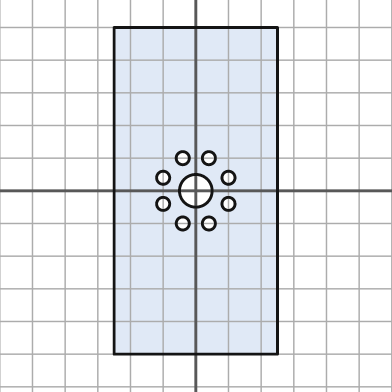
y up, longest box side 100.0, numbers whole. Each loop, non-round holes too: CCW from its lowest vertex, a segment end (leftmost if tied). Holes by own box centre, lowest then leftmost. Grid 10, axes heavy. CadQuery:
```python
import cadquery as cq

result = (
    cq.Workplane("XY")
    .moveTo(-25.0, -50.0)
    .lineTo(25.0, -50.0)
    .lineTo(25.0, 50.0)
    .lineTo(-25.0, 50.0)
    .close()
    .moveTo(-4.0, -10.0)
    .circle(2.0)
    .moveTo(4.0, -10.0)
    .circle(2.0)
    .moveTo(-10.0, -4.0)
    .circle(2.0)
    .moveTo(10.0, -4.0)
    .circle(2.0)
    .moveTo(0.0, 0.0)
    .circle(5.0)
    .moveTo(-10.0, 4.0)
    .circle(2.0)
    .moveTo(10.0, 4.0)
    .circle(2.0)
    .moveTo(-4.0, 10.0)
    .circle(2.0)
    .moveTo(4.0, 10.0)
    .circle(2.0)
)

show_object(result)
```